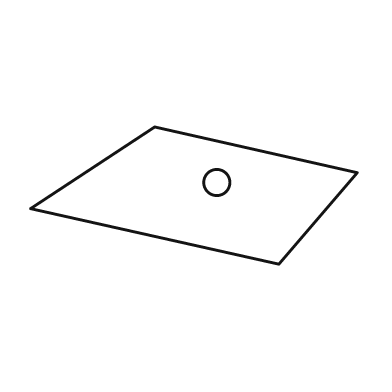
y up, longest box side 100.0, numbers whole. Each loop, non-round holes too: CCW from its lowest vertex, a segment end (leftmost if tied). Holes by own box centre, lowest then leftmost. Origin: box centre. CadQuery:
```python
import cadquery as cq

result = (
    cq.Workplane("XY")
    .moveTo(26.0, -21.0)
    .lineTo(50.0, 7.0)
    .lineTo(-12.0, 21.0)
    .lineTo(-50.0, -4.0)
    .close()
    .moveTo(7.0, 4.0)
    .circle(4.0)
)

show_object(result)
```